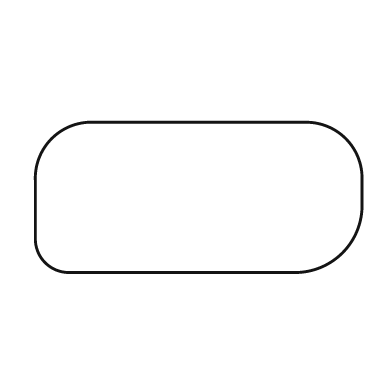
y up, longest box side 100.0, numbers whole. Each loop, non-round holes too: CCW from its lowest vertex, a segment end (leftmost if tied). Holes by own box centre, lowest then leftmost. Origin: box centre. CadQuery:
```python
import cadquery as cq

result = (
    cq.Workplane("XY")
    .moveTo(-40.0, -23.0)
    .lineTo(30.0, -23.0)
    .threePointArc((44.0, -17.0), (50.0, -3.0))
    .lineTo(50.0, 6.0)
    .threePointArc((45.0, 18.0), (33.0, 23.0))
    .lineTo(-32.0, 23.0)
    .threePointArc((-45.0, 18.0), (-50.0, 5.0))
    .lineTo(-50.0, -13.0)
    .threePointArc((-47.0, -20.0), (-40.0, -23.0))
    .close()
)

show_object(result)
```